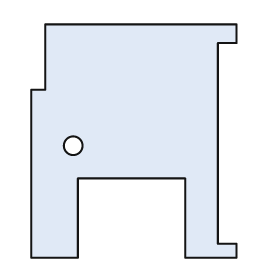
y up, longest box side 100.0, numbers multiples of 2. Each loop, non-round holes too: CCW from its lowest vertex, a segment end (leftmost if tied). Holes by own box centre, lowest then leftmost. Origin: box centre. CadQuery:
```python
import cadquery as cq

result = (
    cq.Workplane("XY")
    .moveTo(-44.0, -50.0)
    .lineTo(-24.0, -50.0)
    .lineTo(-24.0, -16.0)
    .lineTo(22.0, -16.0)
    .lineTo(22.0, -50.0)
    .lineTo(44.0, -50.0)
    .lineTo(44.0, -44.0)
    .lineTo(36.0, -44.0)
    .lineTo(36.0, 42.0)
    .lineTo(44.0, 42.0)
    .lineTo(44.0, 50.0)
    .lineTo(-38.0, 50.0)
    .lineTo(-38.0, 22.0)
    .lineTo(-44.0, 22.0)
    .close()
    .moveTo(-26.0, -2.0)
    .circle(4.0)
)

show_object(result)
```